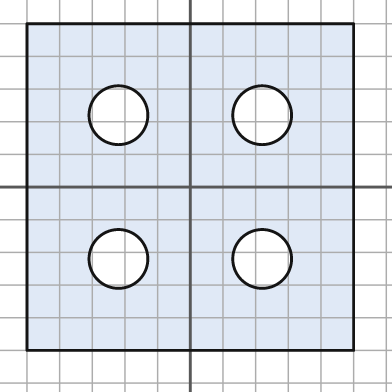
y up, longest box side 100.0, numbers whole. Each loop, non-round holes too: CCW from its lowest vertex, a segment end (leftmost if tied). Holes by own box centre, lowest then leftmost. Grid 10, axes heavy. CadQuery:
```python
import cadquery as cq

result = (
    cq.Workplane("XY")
    .moveTo(-50.0, -50.0)
    .lineTo(50.0, -50.0)
    .lineTo(50.0, 50.0)
    .lineTo(-50.0, 50.0)
    .close()
    .moveTo(-22.0, -22.0)
    .circle(9.0)
    .moveTo(22.0, -22.0)
    .circle(9.0)
    .moveTo(-22.0, 22.0)
    .circle(9.0)
    .moveTo(22.0, 22.0)
    .circle(9.0)
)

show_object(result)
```